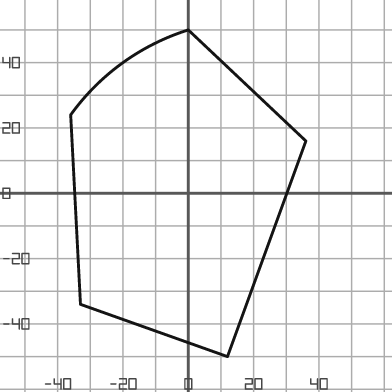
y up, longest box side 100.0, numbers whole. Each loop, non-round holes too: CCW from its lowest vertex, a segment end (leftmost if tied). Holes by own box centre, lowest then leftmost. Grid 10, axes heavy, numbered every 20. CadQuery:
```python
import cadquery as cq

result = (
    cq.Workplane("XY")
    .moveTo(12.0, -50.0)
    .lineTo(36.0, 16.0)
    .lineTo(0.0, 50.0)
    .threePointArc((-20.0, 40.0), (-36.0, 24.0))
    .lineTo(-33.0, -34.0)
    .close()
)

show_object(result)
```